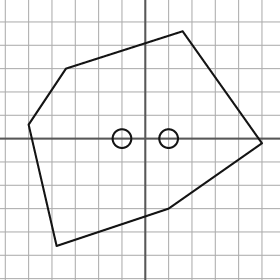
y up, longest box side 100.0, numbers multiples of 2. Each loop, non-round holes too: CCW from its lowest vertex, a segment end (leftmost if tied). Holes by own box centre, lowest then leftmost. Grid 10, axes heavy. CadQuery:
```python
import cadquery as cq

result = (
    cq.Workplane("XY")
    .moveTo(-38.0, -46.0)
    .lineTo(10.0, -30.0)
    .lineTo(50.0, -2.0)
    .lineTo(16.0, 46.0)
    .lineTo(-34.0, 30.0)
    .lineTo(-50.0, 6.0)
    .close()
    .moveTo(-10.0, 0.0)
    .circle(4.0)
    .moveTo(10.0, 0.0)
    .circle(4.0)
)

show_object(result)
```